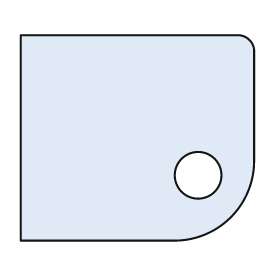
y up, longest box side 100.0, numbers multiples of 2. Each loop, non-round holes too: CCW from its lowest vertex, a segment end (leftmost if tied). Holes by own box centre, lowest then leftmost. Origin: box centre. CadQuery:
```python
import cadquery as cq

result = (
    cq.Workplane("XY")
    .moveTo(-50.0, -44.0)
    .lineTo(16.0, -44.0)
    .threePointArc((40.0, -34.0), (50.0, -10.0))
    .lineTo(50.0, 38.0)
    .threePointArc((48.0, 42.0), (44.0, 44.0))
    .lineTo(-50.0, 44.0)
    .close()
    .moveTo(26.0, -16.0)
    .circle(10.0)
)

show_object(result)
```